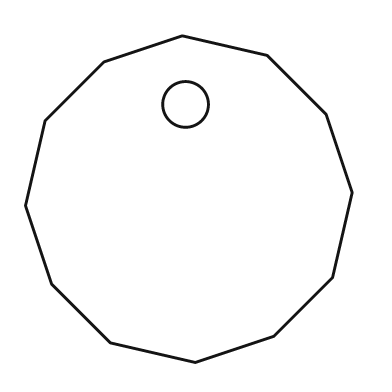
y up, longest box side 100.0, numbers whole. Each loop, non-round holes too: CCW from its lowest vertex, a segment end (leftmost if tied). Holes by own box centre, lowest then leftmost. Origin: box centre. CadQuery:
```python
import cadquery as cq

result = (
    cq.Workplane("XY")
    .moveTo(2.0, -50.0)
    .lineTo(26.0, -42.0)
    .lineTo(44.0, -24.0)
    .lineTo(50.0, 2.0)
    .lineTo(42.0, 26.0)
    .lineTo(24.0, 44.0)
    .lineTo(-2.0, 50.0)
    .lineTo(-26.0, 42.0)
    .lineTo(-44.0, 24.0)
    .lineTo(-50.0, -2.0)
    .lineTo(-42.0, -26.0)
    .lineTo(-24.0, -44.0)
    .close()
    .moveTo(-1.0, 29.0)
    .circle(7.0)
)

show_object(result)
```